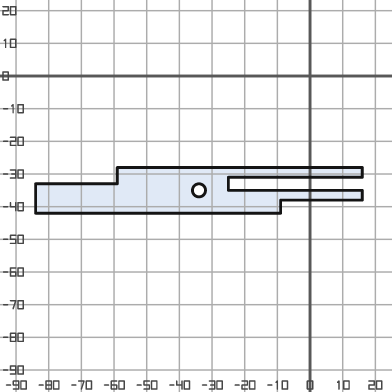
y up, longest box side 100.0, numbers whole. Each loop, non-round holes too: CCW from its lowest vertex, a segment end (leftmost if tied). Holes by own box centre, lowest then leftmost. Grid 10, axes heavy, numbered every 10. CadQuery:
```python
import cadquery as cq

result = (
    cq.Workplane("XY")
    .moveTo(-84.0, -42.0)
    .lineTo(-9.0, -42.0)
    .lineTo(-9.0, -38.0)
    .lineTo(16.0, -38.0)
    .lineTo(16.0, -35.0)
    .lineTo(-25.0, -35.0)
    .lineTo(-25.0, -31.0)
    .lineTo(16.0, -31.0)
    .lineTo(16.0, -28.0)
    .lineTo(-59.0, -28.0)
    .lineTo(-59.0, -33.0)
    .lineTo(-84.0, -33.0)
    .close()
    .moveTo(-34.0, -35.0)
    .circle(2.0)
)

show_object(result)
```